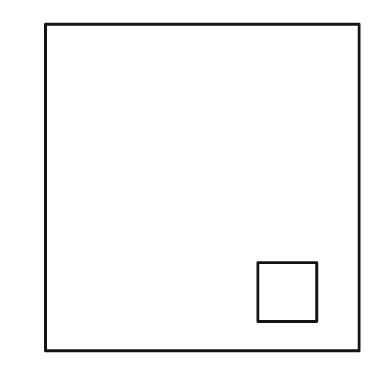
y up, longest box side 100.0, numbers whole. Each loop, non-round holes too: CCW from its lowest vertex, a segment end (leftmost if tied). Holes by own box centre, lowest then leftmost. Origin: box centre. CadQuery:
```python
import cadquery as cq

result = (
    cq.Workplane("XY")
    .moveTo(-48.0, -50.0)
    .lineTo(48.0, -50.0)
    .lineTo(48.0, 50.0)
    .lineTo(-48.0, 50.0)
    .close()
    .moveTo(17.0, -41.0)
    .lineTo(35.0, -41.0)
    .lineTo(35.0, -23.0)
    .lineTo(17.0, -23.0)
    .close()
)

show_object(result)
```